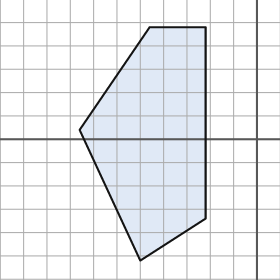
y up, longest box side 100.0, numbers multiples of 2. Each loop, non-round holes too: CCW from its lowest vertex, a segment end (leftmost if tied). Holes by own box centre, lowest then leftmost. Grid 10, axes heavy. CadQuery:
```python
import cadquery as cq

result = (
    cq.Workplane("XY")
    .moveTo(-50.0, -52.0)
    .lineTo(-22.0, -34.0)
    .lineTo(-22.0, 48.0)
    .lineTo(-46.0, 48.0)
    .lineTo(-76.0, 4.0)
    .close()
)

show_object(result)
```